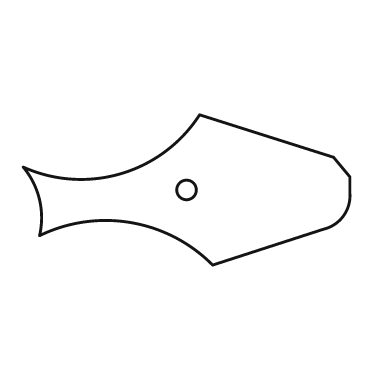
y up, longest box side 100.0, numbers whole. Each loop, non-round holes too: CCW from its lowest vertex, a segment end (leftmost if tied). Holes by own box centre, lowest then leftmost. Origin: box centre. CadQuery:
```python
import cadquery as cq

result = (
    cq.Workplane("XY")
    .moveTo(8.0, -23.0)
    .lineTo(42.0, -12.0)
    .threePointArc((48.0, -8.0), (50.0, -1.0))
    .lineTo(50.0, 4.0)
    .lineTo(45.0, 10.0)
    .lineTo(4.0, 23.0)
    .threePointArc((-20.0, 5.0), (-50.0, 7.0))
    .threePointArc((-45.0, -3.0), (-45.0, -14.0))
    .threePointArc((-17.0, -10.0), (8.0, -23.0))
    .close()
    .moveTo(0.0, 0.0)
    .circle(3.0)
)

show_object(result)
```